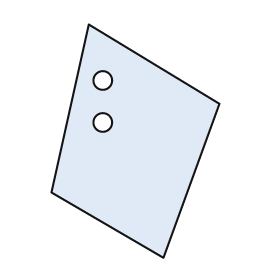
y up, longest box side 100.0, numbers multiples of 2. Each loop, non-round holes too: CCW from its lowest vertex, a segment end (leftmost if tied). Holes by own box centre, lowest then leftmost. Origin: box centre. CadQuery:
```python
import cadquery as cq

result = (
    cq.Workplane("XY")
    .moveTo(12.0, -50.0)
    .lineTo(36.0, 16.0)
    .lineTo(-20.0, 50.0)
    .lineTo(-36.0, -22.0)
    .close()
    .moveTo(-14.0, 8.0)
    .circle(4.0)
    .moveTo(-14.0, 26.0)
    .circle(4.0)
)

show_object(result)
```